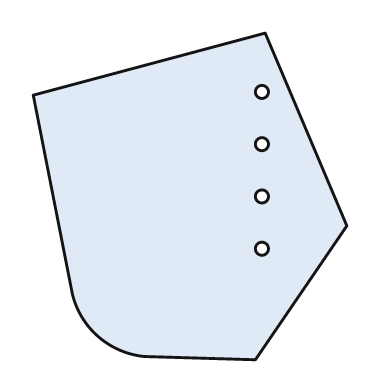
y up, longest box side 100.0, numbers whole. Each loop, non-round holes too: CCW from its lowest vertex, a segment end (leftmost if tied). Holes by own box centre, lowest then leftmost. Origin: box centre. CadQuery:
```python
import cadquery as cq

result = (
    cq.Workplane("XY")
    .moveTo(20.0, -50.0)
    .lineTo(48.0, -9.0)
    .lineTo(23.0, 50.0)
    .lineTo(-48.0, 31.0)
    .lineTo(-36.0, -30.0)
    .threePointArc((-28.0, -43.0), (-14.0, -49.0))
    .close()
    .moveTo(22.0, -16.0)
    .circle(2.0)
    .moveTo(22.0, 0.0)
    .circle(2.0)
    .moveTo(22.0, 16.0)
    .circle(2.0)
    .moveTo(22.0, 32.0)
    .circle(2.0)
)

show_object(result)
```